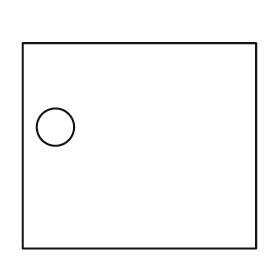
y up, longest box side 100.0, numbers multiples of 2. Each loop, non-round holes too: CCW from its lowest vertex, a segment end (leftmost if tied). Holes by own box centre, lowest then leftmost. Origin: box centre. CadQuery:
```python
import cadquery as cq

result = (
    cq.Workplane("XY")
    .moveTo(-50.0, -44.0)
    .lineTo(50.0, -44.0)
    .lineTo(50.0, 44.0)
    .lineTo(-50.0, 44.0)
    .close()
    .moveTo(-36.0, 8.0)
    .circle(8.0)
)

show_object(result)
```